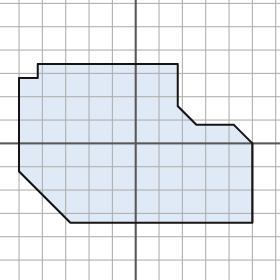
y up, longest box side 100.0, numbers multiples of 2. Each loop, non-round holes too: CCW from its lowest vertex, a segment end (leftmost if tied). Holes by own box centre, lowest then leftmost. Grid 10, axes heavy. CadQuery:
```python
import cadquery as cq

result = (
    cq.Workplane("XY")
    .moveTo(-28.0, -34.0)
    .lineTo(50.0, -34.0)
    .lineTo(50.0, 0.0)
    .lineTo(42.0, 8.0)
    .lineTo(26.0, 8.0)
    .lineTo(18.0, 16.0)
    .lineTo(18.0, 34.0)
    .lineTo(-42.0, 34.0)
    .lineTo(-42.0, 28.0)
    .lineTo(-50.0, 28.0)
    .lineTo(-50.0, -12.0)
    .close()
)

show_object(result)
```